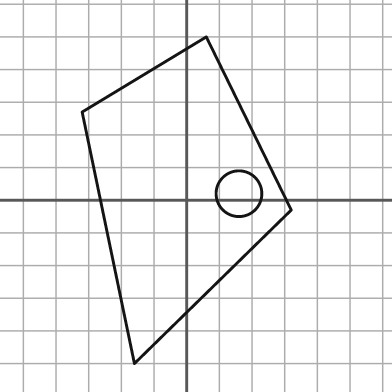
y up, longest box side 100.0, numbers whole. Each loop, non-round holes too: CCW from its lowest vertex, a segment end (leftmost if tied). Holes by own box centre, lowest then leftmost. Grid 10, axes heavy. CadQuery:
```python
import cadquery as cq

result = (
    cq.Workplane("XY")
    .moveTo(-16.0, -50.0)
    .lineTo(32.0, -3.0)
    .lineTo(6.0, 50.0)
    .lineTo(-32.0, 27.0)
    .close()
    .moveTo(16.0, 2.0)
    .circle(7.0)
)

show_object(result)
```